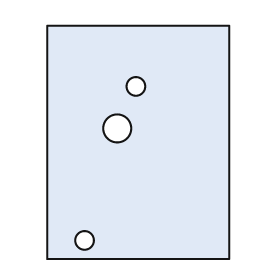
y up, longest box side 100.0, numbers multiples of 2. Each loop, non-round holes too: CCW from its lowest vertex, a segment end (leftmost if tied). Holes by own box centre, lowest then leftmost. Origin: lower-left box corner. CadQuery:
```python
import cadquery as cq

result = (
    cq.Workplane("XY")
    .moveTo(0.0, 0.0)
    .lineTo(78.0, 0.0)
    .lineTo(78.0, 100.0)
    .lineTo(0.0, 100.0)
    .close()
    .moveTo(16.0, 8.0)
    .circle(4.0)
    .moveTo(30.0, 56.0)
    .circle(6.0)
    .moveTo(38.0, 74.0)
    .circle(4.0)
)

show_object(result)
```